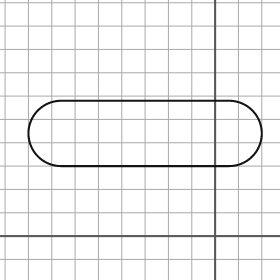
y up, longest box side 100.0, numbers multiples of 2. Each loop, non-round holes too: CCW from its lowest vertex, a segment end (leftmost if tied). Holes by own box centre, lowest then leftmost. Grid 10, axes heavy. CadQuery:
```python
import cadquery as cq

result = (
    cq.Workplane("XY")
    .moveTo(-66.0, 30.0)
    .lineTo(6.0, 30.0)
    .threePointArc((20.0, 44.0), (6.0, 58.0))
    .lineTo(-66.0, 58.0)
    .threePointArc((-80.0, 44.0), (-66.0, 30.0))
    .close()
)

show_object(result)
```